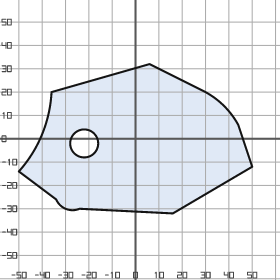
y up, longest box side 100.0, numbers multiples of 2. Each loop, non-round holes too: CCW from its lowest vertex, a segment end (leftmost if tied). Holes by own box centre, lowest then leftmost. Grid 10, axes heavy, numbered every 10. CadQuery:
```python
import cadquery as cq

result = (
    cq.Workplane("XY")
    .moveTo(16.0, -32.0)
    .lineTo(50.0, -12.0)
    .lineTo(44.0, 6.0)
    .threePointArc((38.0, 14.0), (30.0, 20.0))
    .lineTo(6.0, 32.0)
    .lineTo(-36.0, 20.0)
    .threePointArc((-40.0, 2.0), (-50.0, -14.0))
    .lineTo(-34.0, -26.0)
    .threePointArc((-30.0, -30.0), (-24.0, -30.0))
    .close()
    .moveTo(-22.0, -2.0)
    .circle(6.0)
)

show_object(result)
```